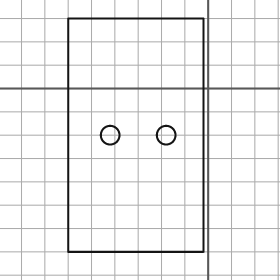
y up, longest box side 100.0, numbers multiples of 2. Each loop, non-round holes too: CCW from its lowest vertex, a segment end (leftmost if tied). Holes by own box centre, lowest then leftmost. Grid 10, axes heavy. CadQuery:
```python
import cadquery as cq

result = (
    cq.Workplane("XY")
    .moveTo(-60.0, -70.0)
    .lineTo(-2.0, -70.0)
    .lineTo(-2.0, 30.0)
    .lineTo(-60.0, 30.0)
    .close()
    .moveTo(-42.0, -20.0)
    .circle(4.0)
    .moveTo(-18.0, -20.0)
    .circle(4.0)
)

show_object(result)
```